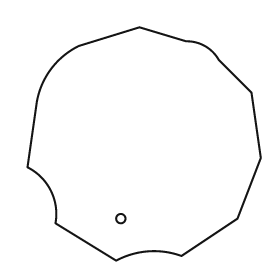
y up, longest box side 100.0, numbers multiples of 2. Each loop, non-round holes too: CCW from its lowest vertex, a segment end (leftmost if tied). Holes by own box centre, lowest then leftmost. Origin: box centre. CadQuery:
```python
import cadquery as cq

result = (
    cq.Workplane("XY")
    .moveTo(-12.0, -50.0)
    .threePointArc((2.0, -46.0), (16.0, -48.0))
    .lineTo(40.0, -32.0)
    .lineTo(50.0, -6.0)
    .lineTo(46.0, 22.0)
    .lineTo(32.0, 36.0)
    .threePointArc((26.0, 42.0), (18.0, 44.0))
    .lineTo(-2.0, 50.0)
    .lineTo(-28.0, 42.0)
    .threePointArc((-40.0, 32.0), (-46.0, 18.0))
    .lineTo(-50.0, -10.0)
    .threePointArc((-40.0, -20.0), (-38.0, -34.0))
    .close()
    .moveTo(-10.0, -32.0)
    .circle(2.0)
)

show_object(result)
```